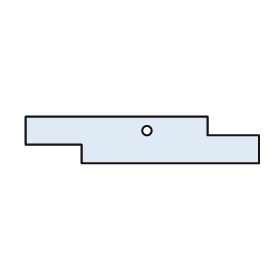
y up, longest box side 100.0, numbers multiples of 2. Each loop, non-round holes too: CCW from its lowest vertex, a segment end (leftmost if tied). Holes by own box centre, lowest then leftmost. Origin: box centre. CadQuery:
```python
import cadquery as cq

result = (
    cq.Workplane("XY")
    .moveTo(-26.0, -10.0)
    .lineTo(50.0, -10.0)
    .lineTo(50.0, 2.0)
    .lineTo(28.0, 2.0)
    .lineTo(28.0, 10.0)
    .lineTo(-50.0, 10.0)
    .lineTo(-50.0, -2.0)
    .lineTo(-26.0, -2.0)
    .close()
    .moveTo(2.0, 4.0)
    .circle(2.0)
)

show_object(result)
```